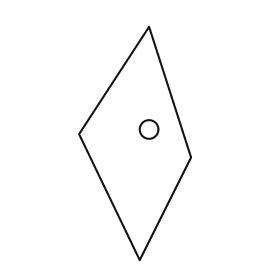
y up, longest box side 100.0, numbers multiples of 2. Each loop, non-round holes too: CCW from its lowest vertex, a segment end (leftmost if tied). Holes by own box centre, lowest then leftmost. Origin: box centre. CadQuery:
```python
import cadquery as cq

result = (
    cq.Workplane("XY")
    .moveTo(2.0, -50.0)
    .lineTo(24.0, -6.0)
    .lineTo(6.0, 50.0)
    .lineTo(-24.0, 4.0)
    .close()
    .moveTo(6.0, 6.0)
    .circle(4.0)
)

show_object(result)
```